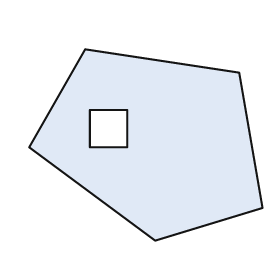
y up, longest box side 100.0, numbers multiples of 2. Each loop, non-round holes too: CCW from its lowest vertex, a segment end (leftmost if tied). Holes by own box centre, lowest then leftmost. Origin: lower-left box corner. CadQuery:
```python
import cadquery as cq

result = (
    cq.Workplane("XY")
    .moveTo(54.0, 0.0)
    .lineTo(100.0, 14.0)
    .lineTo(90.0, 72.0)
    .lineTo(24.0, 82.0)
    .lineTo(0.0, 40.0)
    .close()
    .moveTo(26.0, 40.0)
    .lineTo(42.0, 40.0)
    .lineTo(42.0, 56.0)
    .lineTo(26.0, 56.0)
    .close()
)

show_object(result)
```